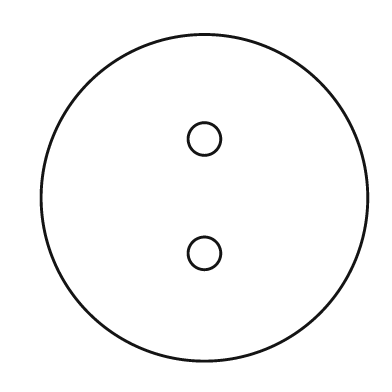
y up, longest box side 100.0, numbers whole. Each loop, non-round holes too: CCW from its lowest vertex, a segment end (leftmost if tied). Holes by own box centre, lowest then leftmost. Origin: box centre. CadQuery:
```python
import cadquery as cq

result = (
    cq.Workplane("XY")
    .moveTo(0.0, 0.0)
    .circle(50.0)
    .moveTo(0.0, -17.0)
    .circle(5.0)
    .moveTo(0.0, 18.0)
    .circle(5.0)
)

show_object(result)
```